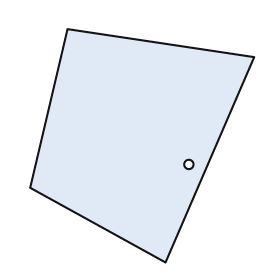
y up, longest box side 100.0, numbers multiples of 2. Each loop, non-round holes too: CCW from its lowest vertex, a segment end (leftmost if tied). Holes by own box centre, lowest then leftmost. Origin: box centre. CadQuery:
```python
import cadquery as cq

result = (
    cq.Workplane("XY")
    .moveTo(10.0, -50.0)
    .lineTo(48.0, 38.0)
    .lineTo(-32.0, 50.0)
    .lineTo(-48.0, -18.0)
    .close()
    .moveTo(20.0, -8.0)
    .circle(2.0)
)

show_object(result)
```